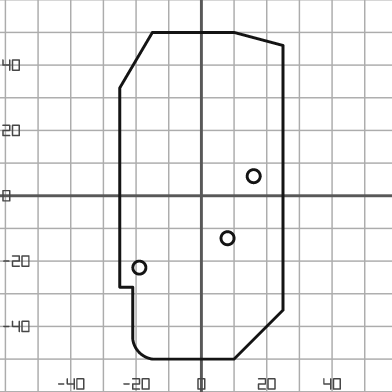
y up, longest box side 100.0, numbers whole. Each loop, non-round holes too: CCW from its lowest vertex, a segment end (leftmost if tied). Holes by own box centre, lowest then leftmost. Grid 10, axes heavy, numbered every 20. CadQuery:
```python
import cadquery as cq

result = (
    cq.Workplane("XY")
    .moveTo(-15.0, -50.0)
    .lineTo(10.0, -50.0)
    .lineTo(25.0, -35.0)
    .lineTo(25.0, 46.0)
    .lineTo(10.0, 50.0)
    .lineTo(-15.0, 50.0)
    .lineTo(-25.0, 33.0)
    .lineTo(-25.0, -28.0)
    .lineTo(-21.0, -28.0)
    .lineTo(-21.0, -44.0)
    .threePointArc((-19.0, -48.0), (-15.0, -50.0))
    .close()
    .moveTo(-19.0, -22.0)
    .circle(2.0)
    .moveTo(8.0, -13.0)
    .circle(2.0)
    .moveTo(16.0, 6.0)
    .circle(2.0)
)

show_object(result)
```